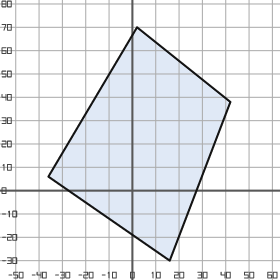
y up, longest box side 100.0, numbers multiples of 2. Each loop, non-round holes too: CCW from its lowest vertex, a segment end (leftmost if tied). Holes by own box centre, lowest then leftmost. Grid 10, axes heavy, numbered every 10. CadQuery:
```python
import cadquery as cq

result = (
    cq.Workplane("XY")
    .moveTo(16.0, -30.0)
    .lineTo(42.0, 38.0)
    .lineTo(2.0, 70.0)
    .lineTo(-36.0, 6.0)
    .close()
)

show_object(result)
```